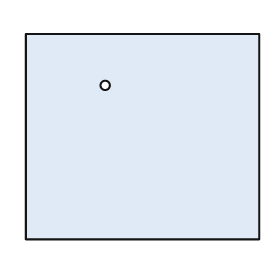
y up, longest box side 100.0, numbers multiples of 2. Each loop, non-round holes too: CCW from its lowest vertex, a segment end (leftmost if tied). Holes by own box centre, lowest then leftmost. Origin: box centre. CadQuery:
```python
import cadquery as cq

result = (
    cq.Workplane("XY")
    .moveTo(-50.0, -44.0)
    .lineTo(50.0, -44.0)
    .lineTo(50.0, 44.0)
    .lineTo(-50.0, 44.0)
    .close()
    .moveTo(-16.0, 22.0)
    .circle(2.0)
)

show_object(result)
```